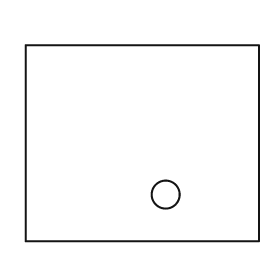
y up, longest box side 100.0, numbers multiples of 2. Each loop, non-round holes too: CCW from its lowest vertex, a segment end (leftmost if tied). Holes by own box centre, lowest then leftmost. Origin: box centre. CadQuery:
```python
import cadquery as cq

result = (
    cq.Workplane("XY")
    .moveTo(-50.0, -42.0)
    .lineTo(50.0, -42.0)
    .lineTo(50.0, 42.0)
    .lineTo(-50.0, 42.0)
    .close()
    .moveTo(10.0, -22.0)
    .circle(6.0)
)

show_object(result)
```